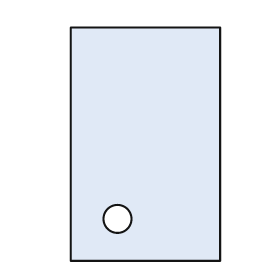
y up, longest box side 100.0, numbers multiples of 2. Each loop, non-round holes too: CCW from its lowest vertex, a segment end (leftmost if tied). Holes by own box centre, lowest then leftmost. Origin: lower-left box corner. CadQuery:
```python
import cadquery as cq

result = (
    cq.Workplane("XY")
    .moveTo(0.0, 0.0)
    .lineTo(64.0, 0.0)
    .lineTo(64.0, 100.0)
    .lineTo(0.0, 100.0)
    .close()
    .moveTo(20.0, 18.0)
    .circle(6.0)
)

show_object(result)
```